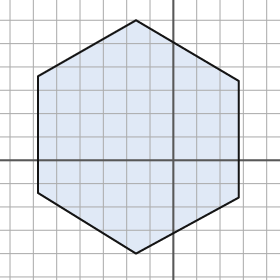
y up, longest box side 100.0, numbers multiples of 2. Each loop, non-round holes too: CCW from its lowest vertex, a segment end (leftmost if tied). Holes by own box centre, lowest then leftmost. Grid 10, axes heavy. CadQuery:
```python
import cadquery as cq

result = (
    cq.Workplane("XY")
    .moveTo(-16.0, -40.0)
    .lineTo(28.0, -16.0)
    .lineTo(28.0, 34.0)
    .lineTo(-16.0, 60.0)
    .lineTo(-58.0, 36.0)
    .lineTo(-58.0, -14.0)
    .close()
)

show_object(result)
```